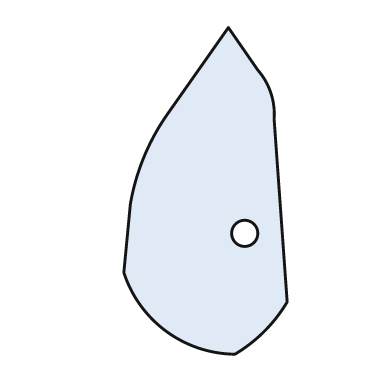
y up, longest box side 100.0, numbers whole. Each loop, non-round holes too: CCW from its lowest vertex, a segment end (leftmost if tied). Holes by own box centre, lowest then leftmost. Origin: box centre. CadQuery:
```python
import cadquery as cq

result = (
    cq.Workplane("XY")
    .moveTo(9.0, -50.0)
    .threePointArc((18.0, -43.0), (25.0, -34.0))
    .lineTo(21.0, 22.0)
    .threePointArc((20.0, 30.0), (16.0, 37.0))
    .lineTo(7.0, 50.0)
    .lineTo(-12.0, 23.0)
    .threePointArc((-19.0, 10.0), (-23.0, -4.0))
    .lineTo(-25.0, -25.0)
    .threePointArc((-12.0, -43.0), (9.0, -50.0))
    .close()
    .moveTo(12.0, -13.0)
    .circle(4.0)
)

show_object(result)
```